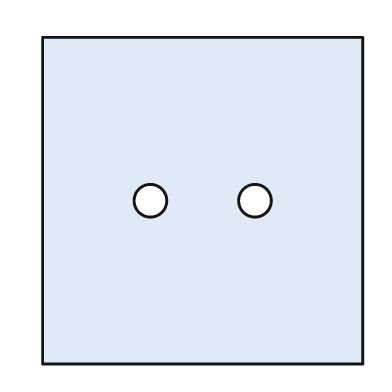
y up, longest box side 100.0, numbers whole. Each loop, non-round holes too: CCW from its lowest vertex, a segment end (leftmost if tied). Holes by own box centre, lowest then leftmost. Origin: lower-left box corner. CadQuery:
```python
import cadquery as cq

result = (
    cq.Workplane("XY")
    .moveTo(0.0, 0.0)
    .lineTo(98.0, 0.0)
    .lineTo(98.0, 100.0)
    .lineTo(0.0, 100.0)
    .close()
    .moveTo(33.0, 50.0)
    .circle(5.0)
    .moveTo(65.0, 50.0)
    .circle(5.0)
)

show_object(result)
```